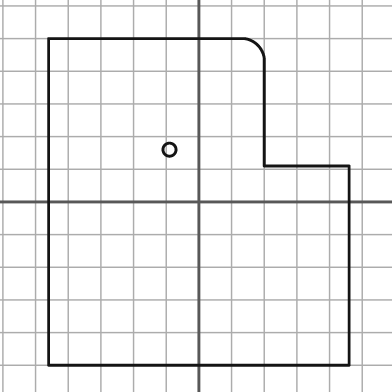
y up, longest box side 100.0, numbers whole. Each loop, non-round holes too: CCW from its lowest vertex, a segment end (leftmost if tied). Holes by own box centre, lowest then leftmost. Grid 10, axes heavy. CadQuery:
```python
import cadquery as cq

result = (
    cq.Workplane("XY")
    .moveTo(-46.0, -50.0)
    .lineTo(46.0, -50.0)
    .lineTo(46.0, 11.0)
    .lineTo(20.0, 11.0)
    .lineTo(20.0, 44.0)
    .threePointArc((18.0, 48.0), (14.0, 50.0))
    .lineTo(-46.0, 50.0)
    .close()
    .moveTo(-9.0, 16.0)
    .circle(2.0)
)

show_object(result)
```